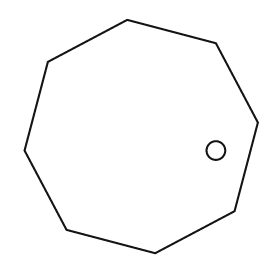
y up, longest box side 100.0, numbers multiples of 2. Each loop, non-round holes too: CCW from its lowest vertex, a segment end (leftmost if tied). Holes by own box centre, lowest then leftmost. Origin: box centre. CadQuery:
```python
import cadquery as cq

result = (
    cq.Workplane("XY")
    .moveTo(6.0, -50.0)
    .lineTo(40.0, -32.0)
    .lineTo(50.0, 6.0)
    .lineTo(32.0, 40.0)
    .lineTo(-6.0, 50.0)
    .lineTo(-40.0, 32.0)
    .lineTo(-50.0, -6.0)
    .lineTo(-32.0, -40.0)
    .close()
    .moveTo(32.0, -6.0)
    .circle(4.0)
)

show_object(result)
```